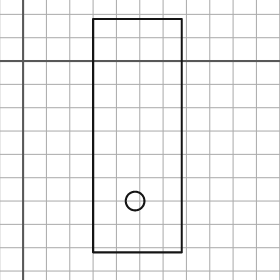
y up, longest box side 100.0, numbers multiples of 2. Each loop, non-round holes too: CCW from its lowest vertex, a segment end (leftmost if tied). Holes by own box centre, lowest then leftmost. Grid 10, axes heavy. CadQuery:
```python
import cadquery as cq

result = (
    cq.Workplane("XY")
    .moveTo(30.0, -82.0)
    .lineTo(68.0, -82.0)
    .lineTo(68.0, 18.0)
    .lineTo(30.0, 18.0)
    .close()
    .moveTo(48.0, -60.0)
    .circle(4.0)
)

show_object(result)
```